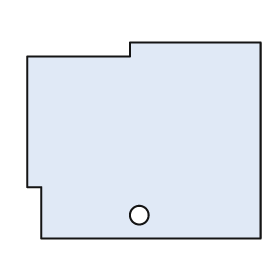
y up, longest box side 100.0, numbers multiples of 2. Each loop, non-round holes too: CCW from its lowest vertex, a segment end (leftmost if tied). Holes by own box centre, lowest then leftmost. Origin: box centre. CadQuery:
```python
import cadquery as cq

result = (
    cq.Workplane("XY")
    .moveTo(-44.0, -42.0)
    .lineTo(50.0, -42.0)
    .lineTo(50.0, 42.0)
    .lineTo(-6.0, 42.0)
    .lineTo(-6.0, 36.0)
    .lineTo(-50.0, 36.0)
    .lineTo(-50.0, -20.0)
    .lineTo(-44.0, -20.0)
    .close()
    .moveTo(-2.0, -32.0)
    .circle(4.0)
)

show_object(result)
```